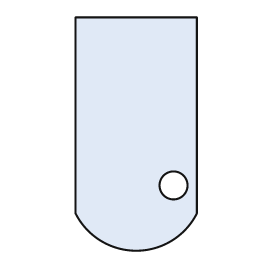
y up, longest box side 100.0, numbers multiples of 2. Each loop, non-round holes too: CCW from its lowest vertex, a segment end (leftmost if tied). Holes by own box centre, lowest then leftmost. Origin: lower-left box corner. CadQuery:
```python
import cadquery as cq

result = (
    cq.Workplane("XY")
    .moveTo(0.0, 16.0)
    .threePointArc((26.0, 0.0), (52.0, 16.0))
    .lineTo(52.0, 100.0)
    .lineTo(0.0, 100.0)
    .close()
    .moveTo(42.0, 28.0)
    .circle(6.0)
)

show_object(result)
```